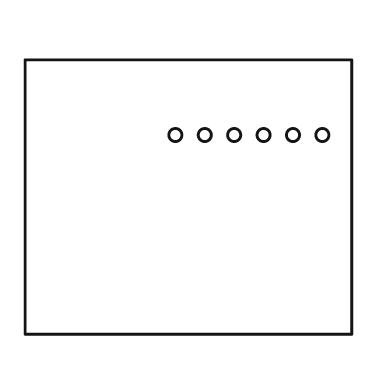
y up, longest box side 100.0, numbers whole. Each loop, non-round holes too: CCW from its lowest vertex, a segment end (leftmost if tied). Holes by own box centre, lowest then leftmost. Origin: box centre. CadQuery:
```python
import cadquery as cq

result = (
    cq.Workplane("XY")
    .moveTo(-50.0, -42.0)
    .lineTo(50.0, -42.0)
    .lineTo(50.0, 42.0)
    .lineTo(-50.0, 42.0)
    .close()
    .moveTo(-4.0, 19.0)
    .circle(2.0)
    .moveTo(5.0, 19.0)
    .circle(2.0)
    .moveTo(14.0, 19.0)
    .circle(2.0)
    .moveTo(23.0, 19.0)
    .circle(2.0)
    .moveTo(32.0, 19.0)
    .circle(2.0)
    .moveTo(41.0, 19.0)
    .circle(2.0)
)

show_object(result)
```